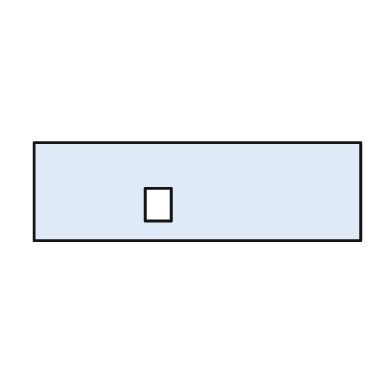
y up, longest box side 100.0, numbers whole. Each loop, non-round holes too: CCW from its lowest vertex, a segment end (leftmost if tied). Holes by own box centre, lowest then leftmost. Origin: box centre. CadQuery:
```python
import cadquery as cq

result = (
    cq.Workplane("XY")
    .moveTo(-50.0, -15.0)
    .lineTo(50.0, -15.0)
    .lineTo(50.0, 15.0)
    .lineTo(-50.0, 15.0)
    .close()
    .moveTo(-16.0, -9.0)
    .lineTo(-8.0, -9.0)
    .lineTo(-8.0, 1.0)
    .lineTo(-16.0, 1.0)
    .close()
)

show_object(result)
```